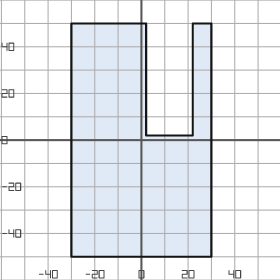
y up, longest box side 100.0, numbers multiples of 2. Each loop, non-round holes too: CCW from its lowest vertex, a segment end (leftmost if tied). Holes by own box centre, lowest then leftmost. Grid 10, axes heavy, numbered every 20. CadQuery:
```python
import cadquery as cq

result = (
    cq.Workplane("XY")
    .moveTo(-30.0, -50.0)
    .lineTo(30.0, -50.0)
    .lineTo(30.0, 50.0)
    .lineTo(22.0, 50.0)
    .lineTo(22.0, 2.0)
    .lineTo(2.0, 2.0)
    .lineTo(2.0, 50.0)
    .lineTo(-30.0, 50.0)
    .close()
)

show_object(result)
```